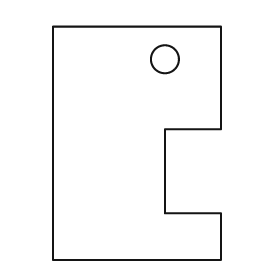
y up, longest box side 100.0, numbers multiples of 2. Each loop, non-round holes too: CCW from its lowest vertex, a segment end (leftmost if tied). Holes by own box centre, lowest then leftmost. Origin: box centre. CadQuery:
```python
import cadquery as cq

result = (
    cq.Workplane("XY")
    .moveTo(-36.0, -50.0)
    .lineTo(36.0, -50.0)
    .lineTo(36.0, -30.0)
    .lineTo(12.0, -30.0)
    .lineTo(12.0, 6.0)
    .lineTo(36.0, 6.0)
    .lineTo(36.0, 50.0)
    .lineTo(-36.0, 50.0)
    .close()
    .moveTo(12.0, 36.0)
    .circle(6.0)
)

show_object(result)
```